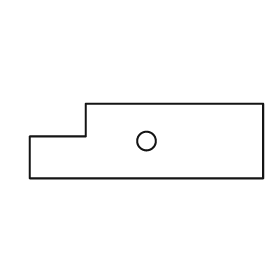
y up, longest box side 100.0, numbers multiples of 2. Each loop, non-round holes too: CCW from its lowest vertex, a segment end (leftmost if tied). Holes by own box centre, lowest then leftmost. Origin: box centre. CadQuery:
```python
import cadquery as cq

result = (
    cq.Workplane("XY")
    .moveTo(-50.0, -16.0)
    .lineTo(50.0, -16.0)
    .lineTo(50.0, 16.0)
    .lineTo(-26.0, 16.0)
    .lineTo(-26.0, 2.0)
    .lineTo(-50.0, 2.0)
    .close()
    .moveTo(0.0, 0.0)
    .circle(4.0)
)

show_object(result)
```